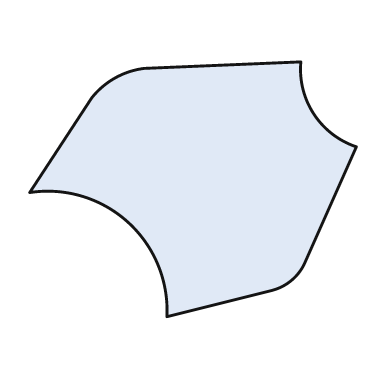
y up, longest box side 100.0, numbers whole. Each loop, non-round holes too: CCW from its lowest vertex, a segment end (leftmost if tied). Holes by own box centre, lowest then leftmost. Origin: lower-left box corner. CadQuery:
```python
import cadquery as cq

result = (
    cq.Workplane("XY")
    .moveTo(42.0, 0.0)
    .lineTo(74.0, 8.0)
    .threePointArc((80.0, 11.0), (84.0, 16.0))
    .lineTo(100.0, 52.0)
    .threePointArc((87.0, 62.0), (83.0, 78.0))
    .lineTo(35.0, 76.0)
    .threePointArc((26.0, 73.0), (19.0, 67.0))
    .lineTo(0.0, 38.0)
    .threePointArc((30.0, 29.0), (42.0, 0.0))
    .close()
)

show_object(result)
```